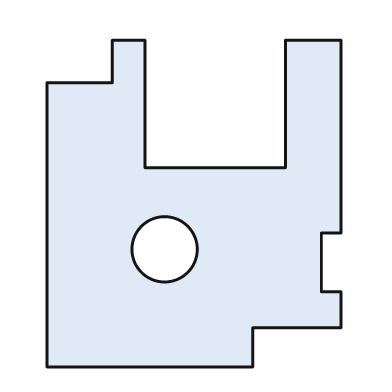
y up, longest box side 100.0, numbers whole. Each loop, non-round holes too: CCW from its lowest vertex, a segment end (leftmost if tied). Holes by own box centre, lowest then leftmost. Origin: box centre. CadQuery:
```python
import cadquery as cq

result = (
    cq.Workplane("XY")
    .moveTo(-45.0, -50.0)
    .lineTo(18.0, -50.0)
    .lineTo(18.0, -38.0)
    .lineTo(45.0, -38.0)
    .lineTo(45.0, -27.0)
    .lineTo(39.0, -27.0)
    .lineTo(39.0, -9.0)
    .lineTo(45.0, -9.0)
    .lineTo(45.0, 50.0)
    .lineTo(28.0, 50.0)
    .lineTo(28.0, 11.0)
    .lineTo(-15.0, 11.0)
    .lineTo(-15.0, 50.0)
    .lineTo(-25.0, 50.0)
    .lineTo(-25.0, 37.0)
    .lineTo(-45.0, 37.0)
    .close()
    .moveTo(-9.0, -14.0)
    .circle(10.0)
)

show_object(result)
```